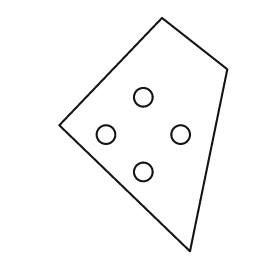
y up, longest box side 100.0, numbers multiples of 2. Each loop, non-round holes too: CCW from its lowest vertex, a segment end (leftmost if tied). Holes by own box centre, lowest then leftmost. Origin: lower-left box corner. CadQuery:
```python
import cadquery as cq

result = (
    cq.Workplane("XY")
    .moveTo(56.0, 0.0)
    .lineTo(72.0, 78.0)
    .lineTo(44.0, 100.0)
    .lineTo(0.0, 54.0)
    .close()
    .moveTo(36.0, 34.0)
    .circle(4.0)
    .moveTo(20.0, 50.0)
    .circle(4.0)
    .moveTo(52.0, 50.0)
    .circle(4.0)
    .moveTo(36.0, 66.0)
    .circle(4.0)
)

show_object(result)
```